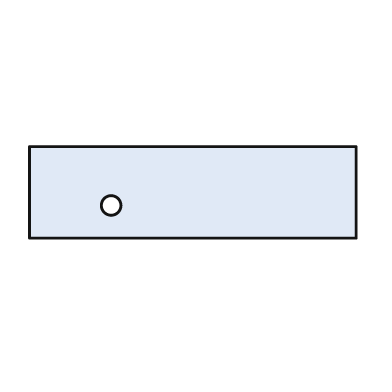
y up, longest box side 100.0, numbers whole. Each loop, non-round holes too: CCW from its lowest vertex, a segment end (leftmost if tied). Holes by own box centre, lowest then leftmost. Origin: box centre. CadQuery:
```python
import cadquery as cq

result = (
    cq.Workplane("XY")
    .moveTo(-50.0, -14.0)
    .lineTo(50.0, -14.0)
    .lineTo(50.0, 14.0)
    .lineTo(-50.0, 14.0)
    .close()
    .moveTo(-25.0, -4.0)
    .circle(3.0)
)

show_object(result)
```